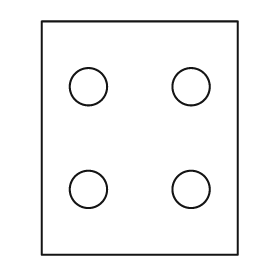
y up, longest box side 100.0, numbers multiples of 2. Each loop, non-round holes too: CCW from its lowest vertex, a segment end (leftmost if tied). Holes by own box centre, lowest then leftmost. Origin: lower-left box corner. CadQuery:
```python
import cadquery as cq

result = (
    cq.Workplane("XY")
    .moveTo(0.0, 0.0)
    .lineTo(84.0, 0.0)
    .lineTo(84.0, 100.0)
    .lineTo(0.0, 100.0)
    .close()
    .moveTo(20.0, 28.0)
    .circle(8.0)
    .moveTo(64.0, 28.0)
    .circle(8.0)
    .moveTo(20.0, 72.0)
    .circle(8.0)
    .moveTo(64.0, 72.0)
    .circle(8.0)
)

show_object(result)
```